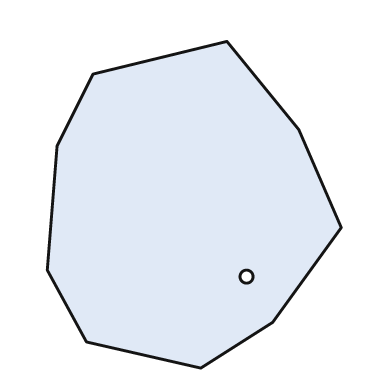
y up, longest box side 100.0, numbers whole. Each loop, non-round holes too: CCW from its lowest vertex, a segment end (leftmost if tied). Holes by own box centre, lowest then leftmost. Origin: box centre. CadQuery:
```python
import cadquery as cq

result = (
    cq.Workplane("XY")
    .moveTo(2.0, -50.0)
    .lineTo(24.0, -36.0)
    .lineTo(45.0, -7.0)
    .lineTo(32.0, 23.0)
    .lineTo(10.0, 50.0)
    .lineTo(-31.0, 40.0)
    .lineTo(-42.0, 18.0)
    .lineTo(-45.0, -20.0)
    .lineTo(-33.0, -42.0)
    .close()
    .moveTo(16.0, -22.0)
    .circle(2.0)
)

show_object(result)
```